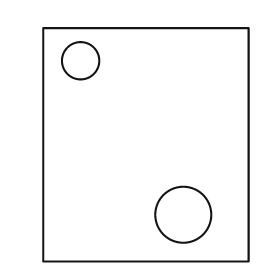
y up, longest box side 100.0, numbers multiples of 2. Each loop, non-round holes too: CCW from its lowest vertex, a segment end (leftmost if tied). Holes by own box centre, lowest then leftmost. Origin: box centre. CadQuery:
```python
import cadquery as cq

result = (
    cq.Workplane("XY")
    .moveTo(-44.0, -50.0)
    .lineTo(44.0, -50.0)
    .lineTo(44.0, 50.0)
    .lineTo(-44.0, 50.0)
    .close()
    .moveTo(16.0, -30.0)
    .circle(12.0)
    .moveTo(-28.0, 36.0)
    .circle(8.0)
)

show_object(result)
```